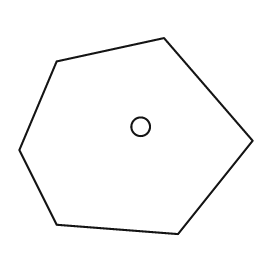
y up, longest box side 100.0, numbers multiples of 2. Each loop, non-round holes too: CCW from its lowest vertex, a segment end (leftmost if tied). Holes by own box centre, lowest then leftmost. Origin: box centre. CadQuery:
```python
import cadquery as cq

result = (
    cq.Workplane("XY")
    .moveTo(18.0, -42.0)
    .lineTo(50.0, -2.0)
    .lineTo(12.0, 42.0)
    .lineTo(-34.0, 32.0)
    .lineTo(-50.0, -6.0)
    .lineTo(-34.0, -38.0)
    .close()
    .moveTo(2.0, 4.0)
    .circle(4.0)
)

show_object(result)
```